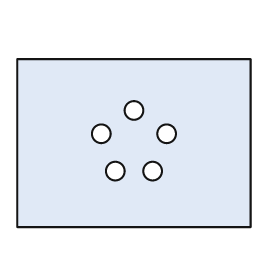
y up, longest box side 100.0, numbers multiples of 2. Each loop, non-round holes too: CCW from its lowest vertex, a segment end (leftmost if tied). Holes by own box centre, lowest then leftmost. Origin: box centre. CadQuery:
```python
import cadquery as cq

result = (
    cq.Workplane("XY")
    .moveTo(-50.0, -36.0)
    .lineTo(50.0, -36.0)
    .lineTo(50.0, 36.0)
    .lineTo(-50.0, 36.0)
    .close()
    .moveTo(-8.0, -12.0)
    .circle(4.0)
    .moveTo(8.0, -12.0)
    .circle(4.0)
    .moveTo(-14.0, 4.0)
    .circle(4.0)
    .moveTo(14.0, 4.0)
    .circle(4.0)
    .moveTo(0.0, 14.0)
    .circle(4.0)
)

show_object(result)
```